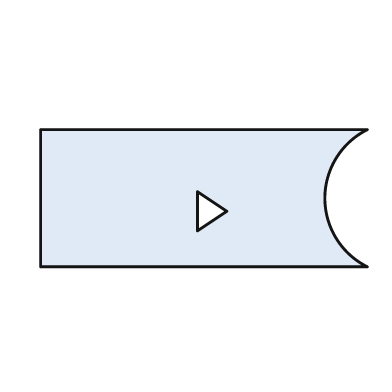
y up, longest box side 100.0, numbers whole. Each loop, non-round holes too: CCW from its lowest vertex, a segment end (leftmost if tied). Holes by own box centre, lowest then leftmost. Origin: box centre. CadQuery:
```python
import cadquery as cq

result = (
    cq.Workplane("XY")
    .moveTo(-50.0, -21.0)
    .lineTo(50.0, -21.0)
    .threePointArc((37.0, 0.0), (50.0, 21.0))
    .lineTo(-50.0, 21.0)
    .close()
    .moveTo(-2.0, -10.0)
    .lineTo(7.0, -4.0)
    .lineTo(-2.0, 2.0)
    .close()
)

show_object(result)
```